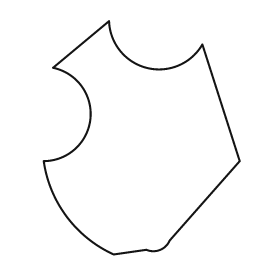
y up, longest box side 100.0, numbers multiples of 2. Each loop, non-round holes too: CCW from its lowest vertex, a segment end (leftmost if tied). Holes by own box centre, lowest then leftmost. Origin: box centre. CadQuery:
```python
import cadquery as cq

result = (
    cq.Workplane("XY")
    .moveTo(-12.0, -50.0)
    .lineTo(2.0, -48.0)
    .threePointArc((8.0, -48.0), (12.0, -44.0))
    .lineTo(42.0, -10.0)
    .lineTo(26.0, 40.0)
    .threePointArc((2.0, 30.0), (-14.0, 50.0))
    .lineTo(-38.0, 30.0)
    .threePointArc((-22.0, 8.0), (-42.0, -10.0))
    .threePointArc((-32.0, -34.0), (-12.0, -50.0))
    .close()
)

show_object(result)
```